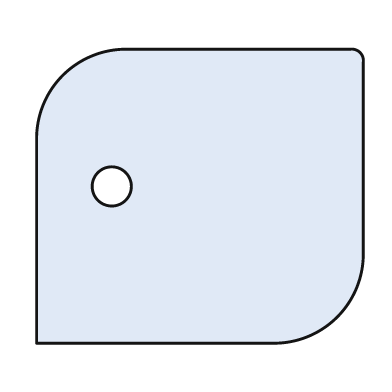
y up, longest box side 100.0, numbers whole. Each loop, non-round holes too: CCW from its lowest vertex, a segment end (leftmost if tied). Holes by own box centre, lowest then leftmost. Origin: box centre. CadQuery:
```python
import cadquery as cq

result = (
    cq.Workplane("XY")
    .moveTo(-50.0, -45.0)
    .lineTo(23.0, -45.0)
    .threePointArc((42.0, -37.0), (50.0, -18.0))
    .lineTo(50.0, 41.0)
    .threePointArc((49.0, 44.0), (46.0, 45.0))
    .lineTo(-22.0, 45.0)
    .threePointArc((-42.0, 37.0), (-50.0, 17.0))
    .close()
    .moveTo(-27.0, 3.0)
    .circle(6.0)
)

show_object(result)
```